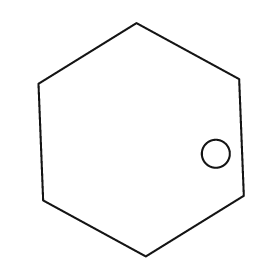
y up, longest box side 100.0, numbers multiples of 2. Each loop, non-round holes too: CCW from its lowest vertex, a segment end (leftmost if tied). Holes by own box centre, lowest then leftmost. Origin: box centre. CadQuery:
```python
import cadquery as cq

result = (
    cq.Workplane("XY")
    .moveTo(2.0, -50.0)
    .lineTo(44.0, -24.0)
    .lineTo(42.0, 26.0)
    .lineTo(-2.0, 50.0)
    .lineTo(-44.0, 24.0)
    .lineTo(-42.0, -26.0)
    .close()
    .moveTo(32.0, -6.0)
    .circle(6.0)
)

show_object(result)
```